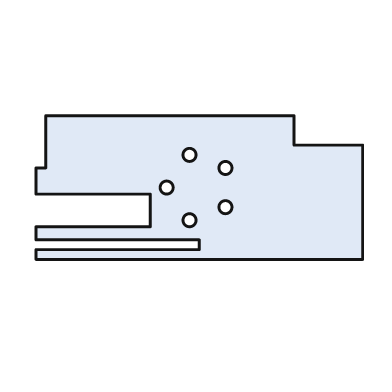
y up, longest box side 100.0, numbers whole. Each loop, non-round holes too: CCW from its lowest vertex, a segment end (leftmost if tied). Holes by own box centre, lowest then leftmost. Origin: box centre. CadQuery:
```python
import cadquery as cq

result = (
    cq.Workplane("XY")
    .moveTo(-50.0, -22.0)
    .lineTo(50.0, -22.0)
    .lineTo(50.0, 13.0)
    .lineTo(29.0, 13.0)
    .lineTo(29.0, 22.0)
    .lineTo(-47.0, 22.0)
    .lineTo(-47.0, 6.0)
    .lineTo(-50.0, 6.0)
    .lineTo(-50.0, -2.0)
    .lineTo(-15.0, -2.0)
    .lineTo(-15.0, -12.0)
    .lineTo(-50.0, -12.0)
    .lineTo(-50.0, -16.0)
    .lineTo(0.0, -16.0)
    .lineTo(0.0, -19.0)
    .lineTo(-50.0, -19.0)
    .close()
    .moveTo(-3.0, -10.0)
    .circle(2.0)
    .moveTo(8.0, -6.0)
    .circle(2.0)
    .moveTo(-10.0, 0.0)
    .circle(2.0)
    .moveTo(8.0, 6.0)
    .circle(2.0)
    .moveTo(-3.0, 10.0)
    .circle(2.0)
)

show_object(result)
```